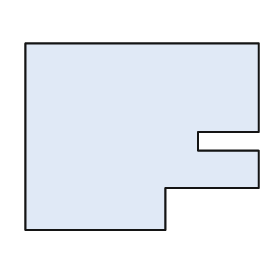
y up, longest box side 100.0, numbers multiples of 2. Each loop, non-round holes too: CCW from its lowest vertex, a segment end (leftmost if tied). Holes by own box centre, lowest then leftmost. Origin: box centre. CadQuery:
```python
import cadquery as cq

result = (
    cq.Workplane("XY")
    .moveTo(-50.0, -40.0)
    .lineTo(10.0, -40.0)
    .lineTo(10.0, -22.0)
    .lineTo(50.0, -22.0)
    .lineTo(50.0, -6.0)
    .lineTo(24.0, -6.0)
    .lineTo(24.0, 2.0)
    .lineTo(50.0, 2.0)
    .lineTo(50.0, 40.0)
    .lineTo(-50.0, 40.0)
    .close()
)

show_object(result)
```